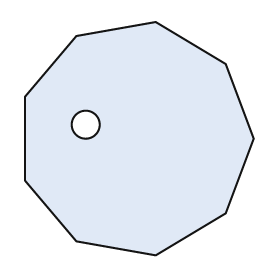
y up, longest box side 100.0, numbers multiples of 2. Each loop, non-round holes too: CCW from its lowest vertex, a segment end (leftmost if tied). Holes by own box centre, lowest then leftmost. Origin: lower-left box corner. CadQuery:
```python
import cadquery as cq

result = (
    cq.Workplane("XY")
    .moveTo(56.0, 0.0)
    .lineTo(86.0, 18.0)
    .lineTo(98.0, 50.0)
    .lineTo(86.0, 82.0)
    .lineTo(56.0, 100.0)
    .lineTo(22.0, 94.0)
    .lineTo(0.0, 68.0)
    .lineTo(0.0, 32.0)
    .lineTo(22.0, 6.0)
    .close()
    .moveTo(26.0, 56.0)
    .circle(6.0)
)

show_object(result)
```